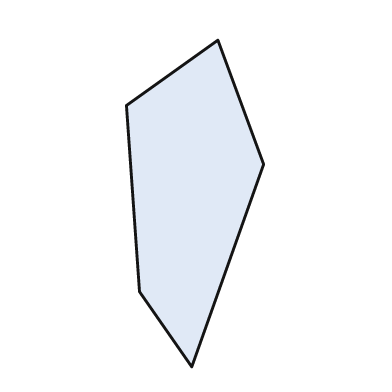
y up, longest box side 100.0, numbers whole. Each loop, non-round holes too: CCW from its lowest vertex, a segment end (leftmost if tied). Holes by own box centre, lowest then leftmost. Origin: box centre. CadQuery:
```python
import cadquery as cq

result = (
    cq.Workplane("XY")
    .moveTo(-1.0, -50.0)
    .lineTo(21.0, 12.0)
    .lineTo(7.0, 50.0)
    .lineTo(-21.0, 30.0)
    .lineTo(-17.0, -27.0)
    .close()
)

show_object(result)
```